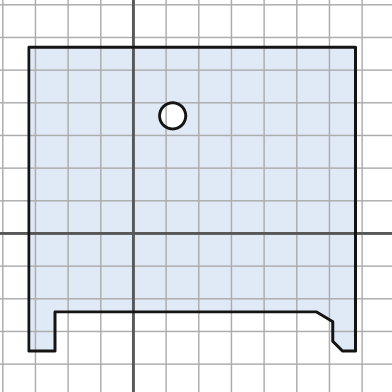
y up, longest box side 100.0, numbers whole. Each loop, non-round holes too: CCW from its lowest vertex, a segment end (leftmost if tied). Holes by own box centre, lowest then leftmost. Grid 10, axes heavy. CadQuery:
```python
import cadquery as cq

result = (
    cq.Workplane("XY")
    .moveTo(-32.0, -36.0)
    .lineTo(-24.0, -36.0)
    .lineTo(-24.0, -24.0)
    .lineTo(56.0, -24.0)
    .lineTo(61.0, -27.0)
    .lineTo(61.0, -33.0)
    .lineTo(64.0, -36.0)
    .lineTo(68.0, -36.0)
    .lineTo(68.0, 57.0)
    .lineTo(-32.0, 57.0)
    .close()
    .moveTo(12.0, 36.0)
    .circle(4.0)
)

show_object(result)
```